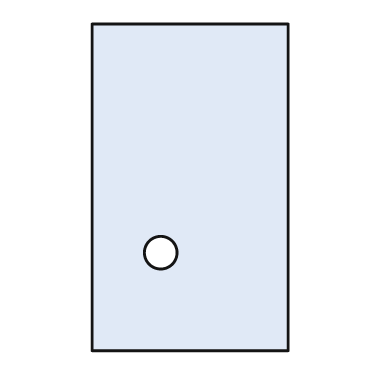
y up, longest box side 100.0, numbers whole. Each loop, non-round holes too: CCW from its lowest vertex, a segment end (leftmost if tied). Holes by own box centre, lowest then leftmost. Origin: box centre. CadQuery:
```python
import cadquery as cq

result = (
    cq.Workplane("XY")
    .moveTo(-30.0, -50.0)
    .lineTo(30.0, -50.0)
    .lineTo(30.0, 50.0)
    .lineTo(-30.0, 50.0)
    .close()
    .moveTo(-9.0, -20.0)
    .circle(5.0)
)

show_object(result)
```